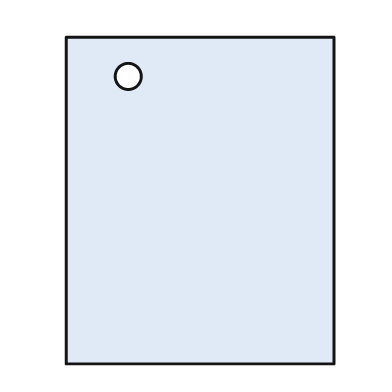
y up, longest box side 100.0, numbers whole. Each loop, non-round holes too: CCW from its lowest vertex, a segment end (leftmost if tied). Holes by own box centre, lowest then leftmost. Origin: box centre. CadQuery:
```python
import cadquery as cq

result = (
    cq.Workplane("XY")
    .moveTo(-41.0, -50.0)
    .lineTo(41.0, -50.0)
    .lineTo(41.0, 50.0)
    .lineTo(-41.0, 50.0)
    .close()
    .moveTo(-22.0, 38.0)
    .circle(4.0)
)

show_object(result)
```